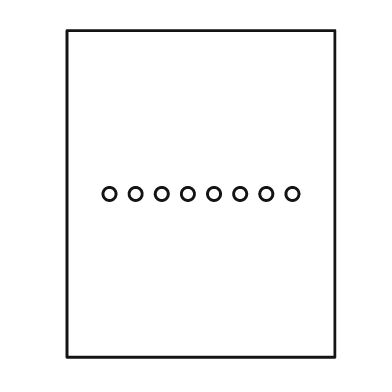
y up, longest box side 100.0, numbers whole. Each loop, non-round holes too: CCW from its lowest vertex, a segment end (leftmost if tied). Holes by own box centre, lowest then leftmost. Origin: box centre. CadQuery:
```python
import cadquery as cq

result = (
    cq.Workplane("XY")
    .moveTo(-41.0, -50.0)
    .lineTo(41.0, -50.0)
    .lineTo(41.0, 50.0)
    .lineTo(-41.0, 50.0)
    .close()
    .moveTo(-28.0, 0.0)
    .circle(2.0)
    .moveTo(-20.0, 0.0)
    .circle(2.0)
    .moveTo(-12.0, 0.0)
    .circle(2.0)
    .moveTo(-4.0, 0.0)
    .circle(2.0)
    .moveTo(4.0, 0.0)
    .circle(2.0)
    .moveTo(12.0, 0.0)
    .circle(2.0)
    .moveTo(20.0, 0.0)
    .circle(2.0)
    .moveTo(28.0, 0.0)
    .circle(2.0)
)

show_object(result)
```